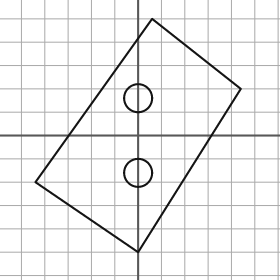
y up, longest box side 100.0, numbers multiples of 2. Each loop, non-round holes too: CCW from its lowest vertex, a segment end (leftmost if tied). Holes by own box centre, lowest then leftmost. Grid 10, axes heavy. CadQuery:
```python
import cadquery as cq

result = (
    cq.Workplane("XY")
    .moveTo(0.0, -50.0)
    .lineTo(44.0, 20.0)
    .lineTo(6.0, 50.0)
    .lineTo(-44.0, -20.0)
    .close()
    .moveTo(0.0, -16.0)
    .circle(6.0)
    .moveTo(0.0, 16.0)
    .circle(6.0)
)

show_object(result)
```